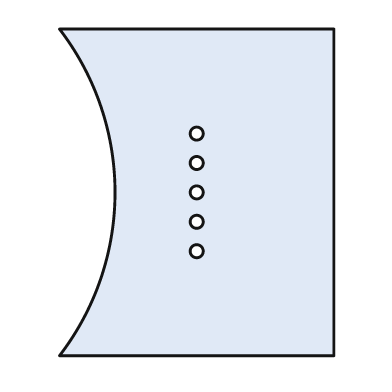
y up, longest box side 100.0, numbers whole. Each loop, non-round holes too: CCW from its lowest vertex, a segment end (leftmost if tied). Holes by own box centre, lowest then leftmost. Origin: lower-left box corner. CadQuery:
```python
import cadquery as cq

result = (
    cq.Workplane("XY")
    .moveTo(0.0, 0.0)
    .lineTo(84.0, 0.0)
    .lineTo(84.0, 100.0)
    .lineTo(0.0, 100.0)
    .threePointArc((17.0, 50.0), (0.0, 0.0))
    .close()
    .moveTo(42.0, 32.0)
    .circle(2.0)
    .moveTo(42.0, 41.0)
    .circle(2.0)
    .moveTo(42.0, 50.0)
    .circle(2.0)
    .moveTo(42.0, 59.0)
    .circle(2.0)
    .moveTo(42.0, 68.0)
    .circle(2.0)
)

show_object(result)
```